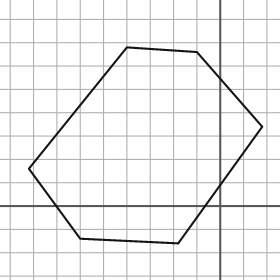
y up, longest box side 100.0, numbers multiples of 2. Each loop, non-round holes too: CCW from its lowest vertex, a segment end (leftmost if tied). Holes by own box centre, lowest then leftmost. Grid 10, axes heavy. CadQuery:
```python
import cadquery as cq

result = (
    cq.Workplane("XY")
    .moveTo(-18.0, -16.0)
    .lineTo(18.0, 34.0)
    .lineTo(-10.0, 66.0)
    .lineTo(-40.0, 68.0)
    .lineTo(-82.0, 16.0)
    .lineTo(-60.0, -14.0)
    .close()
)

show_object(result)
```